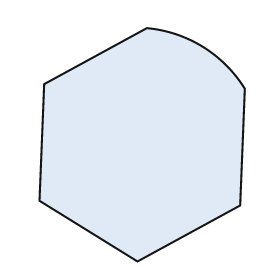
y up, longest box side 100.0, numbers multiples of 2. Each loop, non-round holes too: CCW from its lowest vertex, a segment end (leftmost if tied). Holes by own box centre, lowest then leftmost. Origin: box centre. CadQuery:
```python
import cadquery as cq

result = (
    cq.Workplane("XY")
    .moveTo(-2.0, -50.0)
    .lineTo(42.0, -26.0)
    .lineTo(44.0, 24.0)
    .threePointArc((26.0, 42.0), (2.0, 50.0))
    .lineTo(-42.0, 26.0)
    .lineTo(-44.0, -24.0)
    .close()
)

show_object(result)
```